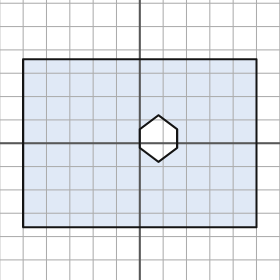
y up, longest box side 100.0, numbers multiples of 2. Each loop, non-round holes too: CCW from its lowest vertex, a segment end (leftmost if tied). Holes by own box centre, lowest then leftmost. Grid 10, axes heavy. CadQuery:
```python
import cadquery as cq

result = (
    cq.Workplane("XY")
    .moveTo(-50.0, -36.0)
    .lineTo(50.0, -36.0)
    .lineTo(50.0, 36.0)
    .lineTo(-50.0, 36.0)
    .close()
    .moveTo(8.0, -8.0)
    .lineTo(16.0, -2.0)
    .lineTo(16.0, 6.0)
    .lineTo(8.0, 12.0)
    .lineTo(0.0, 6.0)
    .lineTo(0.0, -2.0)
    .close()
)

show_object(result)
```